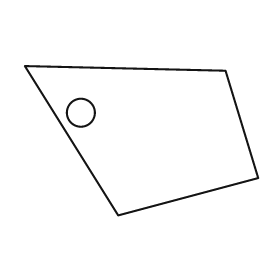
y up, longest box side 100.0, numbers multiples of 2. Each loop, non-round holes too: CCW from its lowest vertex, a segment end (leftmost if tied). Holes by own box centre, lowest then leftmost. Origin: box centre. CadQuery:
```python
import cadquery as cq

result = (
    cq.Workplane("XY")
    .moveTo(-10.0, -32.0)
    .lineTo(50.0, -16.0)
    .lineTo(36.0, 30.0)
    .lineTo(-50.0, 32.0)
    .close()
    .moveTo(-26.0, 12.0)
    .circle(6.0)
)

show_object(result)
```